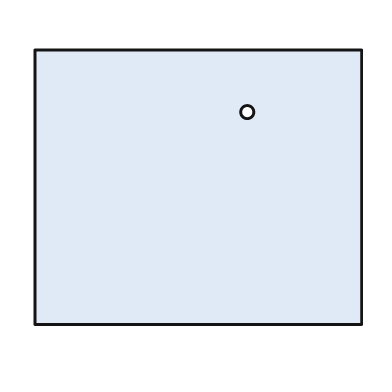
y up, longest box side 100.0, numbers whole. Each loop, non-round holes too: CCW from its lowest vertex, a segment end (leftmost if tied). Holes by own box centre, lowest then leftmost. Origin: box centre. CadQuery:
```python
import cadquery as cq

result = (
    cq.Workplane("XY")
    .moveTo(-50.0, -42.0)
    .lineTo(50.0, -42.0)
    .lineTo(50.0, 42.0)
    .lineTo(-50.0, 42.0)
    .close()
    .moveTo(15.0, 23.0)
    .circle(2.0)
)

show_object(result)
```